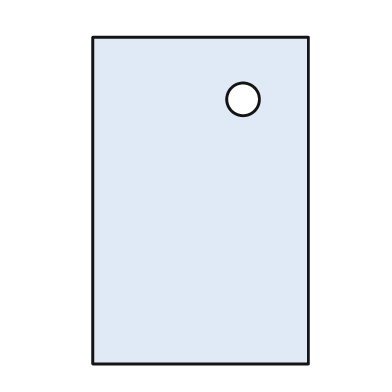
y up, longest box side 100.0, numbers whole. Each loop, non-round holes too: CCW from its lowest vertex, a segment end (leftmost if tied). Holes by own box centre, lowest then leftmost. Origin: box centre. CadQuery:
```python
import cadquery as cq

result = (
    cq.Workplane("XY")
    .moveTo(-33.0, -50.0)
    .lineTo(33.0, -50.0)
    .lineTo(33.0, 50.0)
    .lineTo(-33.0, 50.0)
    .close()
    .moveTo(13.0, 31.0)
    .circle(5.0)
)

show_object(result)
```